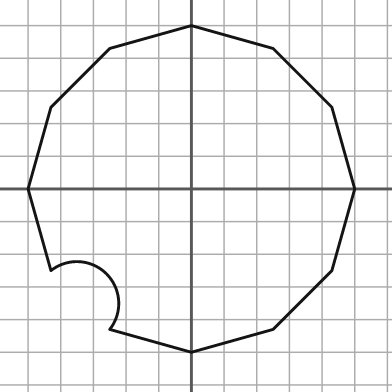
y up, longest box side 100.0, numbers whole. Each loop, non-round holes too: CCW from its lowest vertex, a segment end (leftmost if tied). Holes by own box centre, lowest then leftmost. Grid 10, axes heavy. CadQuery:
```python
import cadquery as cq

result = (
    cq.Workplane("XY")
    .moveTo(0.0, -50.0)
    .lineTo(25.0, -43.0)
    .lineTo(43.0, -25.0)
    .lineTo(50.0, 0.0)
    .lineTo(43.0, 25.0)
    .lineTo(25.0, 43.0)
    .lineTo(0.0, 50.0)
    .lineTo(-25.0, 43.0)
    .lineTo(-43.0, 25.0)
    .lineTo(-50.0, 0.0)
    .lineTo(-43.0, -25.0)
    .threePointArc((-26.0, -26.0), (-25.0, -43.0))
    .close()
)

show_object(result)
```